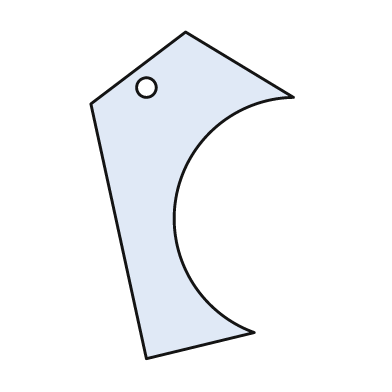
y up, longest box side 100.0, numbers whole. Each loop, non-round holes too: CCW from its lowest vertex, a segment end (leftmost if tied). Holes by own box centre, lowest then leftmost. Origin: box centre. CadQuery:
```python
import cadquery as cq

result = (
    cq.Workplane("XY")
    .moveTo(-14.0, -50.0)
    .lineTo(19.0, -42.0)
    .threePointArc((-5.0, -1.0), (31.0, 30.0))
    .lineTo(-2.0, 50.0)
    .lineTo(-31.0, 28.0)
    .close()
    .moveTo(-14.0, 33.0)
    .circle(3.0)
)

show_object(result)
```